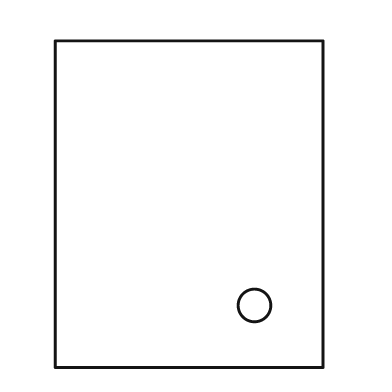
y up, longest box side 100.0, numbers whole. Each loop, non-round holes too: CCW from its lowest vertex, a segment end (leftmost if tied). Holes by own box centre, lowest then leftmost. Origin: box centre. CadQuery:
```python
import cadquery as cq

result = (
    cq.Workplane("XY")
    .moveTo(-41.0, -50.0)
    .lineTo(41.0, -50.0)
    .lineTo(41.0, 50.0)
    .lineTo(-41.0, 50.0)
    .close()
    .moveTo(20.0, -31.0)
    .circle(5.0)
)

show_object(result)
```